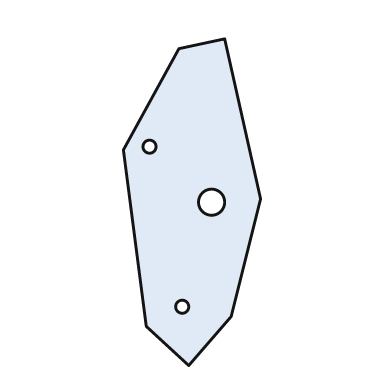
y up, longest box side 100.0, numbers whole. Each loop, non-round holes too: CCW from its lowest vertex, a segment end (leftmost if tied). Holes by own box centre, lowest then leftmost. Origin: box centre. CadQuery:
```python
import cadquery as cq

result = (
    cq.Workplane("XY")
    .moveTo(-1.0, -50.0)
    .lineTo(12.0, -35.0)
    .lineTo(21.0, 1.0)
    .lineTo(10.0, 50.0)
    .lineTo(-4.0, 47.0)
    .lineTo(-21.0, 16.0)
    .lineTo(-14.0, -38.0)
    .close()
    .moveTo(-3.0, -32.0)
    .circle(2.0)
    .moveTo(6.0, 0.0)
    .circle(4.0)
    .moveTo(-13.0, 17.0)
    .circle(2.0)
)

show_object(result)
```